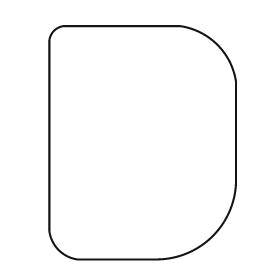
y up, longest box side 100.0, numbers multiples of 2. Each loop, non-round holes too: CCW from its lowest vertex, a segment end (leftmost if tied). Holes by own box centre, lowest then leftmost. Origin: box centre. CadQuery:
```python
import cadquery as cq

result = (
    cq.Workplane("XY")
    .moveTo(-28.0, -50.0)
    .lineTo(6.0, -50.0)
    .threePointArc((30.0, -40.0), (40.0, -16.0))
    .lineTo(40.0, 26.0)
    .threePointArc((32.0, 42.0), (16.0, 50.0))
    .lineTo(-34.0, 50.0)
    .threePointArc((-38.0, 48.0), (-40.0, 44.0))
    .lineTo(-40.0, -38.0)
    .threePointArc((-36.0, -46.0), (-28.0, -50.0))
    .close()
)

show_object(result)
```